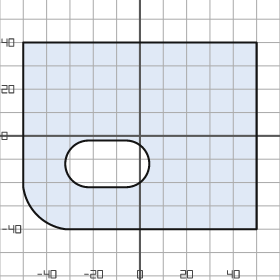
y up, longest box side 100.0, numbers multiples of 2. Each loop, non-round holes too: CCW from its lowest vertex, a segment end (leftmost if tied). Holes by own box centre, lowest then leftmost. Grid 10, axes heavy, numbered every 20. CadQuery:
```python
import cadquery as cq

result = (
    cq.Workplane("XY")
    .moveTo(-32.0, -40.0)
    .lineTo(50.0, -40.0)
    .lineTo(50.0, 40.0)
    .lineTo(-50.0, 40.0)
    .lineTo(-50.0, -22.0)
    .threePointArc((-44.0, -34.0), (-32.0, -40.0))
    .close()
    .moveTo(-22.0, -22.0)
    .lineTo(-6.0, -22.0)
    .threePointArc((4.0, -12.0), (-6.0, -2.0))
    .lineTo(-22.0, -2.0)
    .threePointArc((-32.0, -12.0), (-22.0, -22.0))
    .close()
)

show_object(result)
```